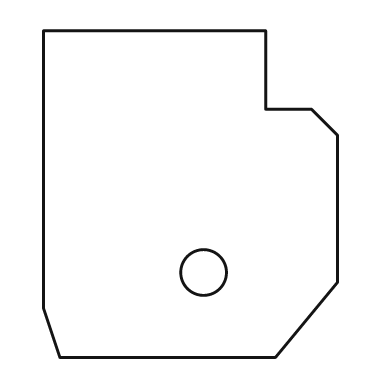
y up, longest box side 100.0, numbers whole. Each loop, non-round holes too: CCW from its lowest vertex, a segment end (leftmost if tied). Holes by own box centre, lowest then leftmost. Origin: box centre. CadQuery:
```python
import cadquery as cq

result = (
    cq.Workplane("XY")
    .moveTo(-40.0, -50.0)
    .lineTo(26.0, -50.0)
    .lineTo(45.0, -27.0)
    .lineTo(45.0, 18.0)
    .lineTo(37.0, 26.0)
    .lineTo(23.0, 26.0)
    .lineTo(23.0, 50.0)
    .lineTo(-45.0, 50.0)
    .lineTo(-45.0, -35.0)
    .close()
    .moveTo(4.0, -24.0)
    .circle(7.0)
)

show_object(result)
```